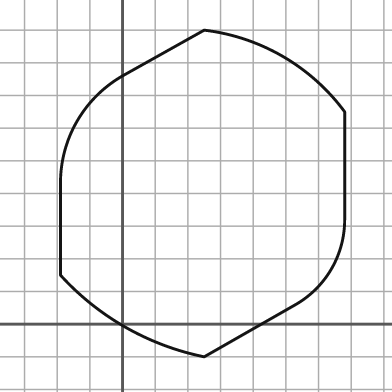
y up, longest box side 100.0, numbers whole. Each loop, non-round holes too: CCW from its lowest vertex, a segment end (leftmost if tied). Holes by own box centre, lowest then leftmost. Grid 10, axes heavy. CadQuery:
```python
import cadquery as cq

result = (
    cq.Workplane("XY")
    .moveTo(25.0, -10.0)
    .lineTo(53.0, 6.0)
    .threePointArc((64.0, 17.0), (68.0, 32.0))
    .lineTo(68.0, 65.0)
    .threePointArc((49.0, 82.0), (25.0, 90.0))
    .lineTo(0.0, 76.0)
    .threePointArc((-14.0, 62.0), (-19.0, 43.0))
    .lineTo(-19.0, 15.0)
    .threePointArc((1.0, -1.0), (25.0, -10.0))
    .close()
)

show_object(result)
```